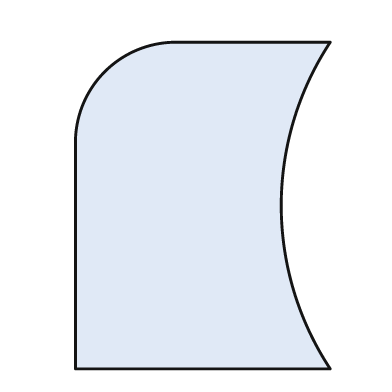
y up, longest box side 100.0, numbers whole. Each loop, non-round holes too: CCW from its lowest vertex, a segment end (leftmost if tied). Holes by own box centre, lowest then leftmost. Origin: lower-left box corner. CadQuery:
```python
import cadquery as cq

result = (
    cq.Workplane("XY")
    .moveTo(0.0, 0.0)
    .lineTo(78.0, 0.0)
    .threePointArc((63.0, 50.0), (78.0, 100.0))
    .lineTo(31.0, 100.0)
    .threePointArc((9.0, 91.0), (0.0, 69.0))
    .close()
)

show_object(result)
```